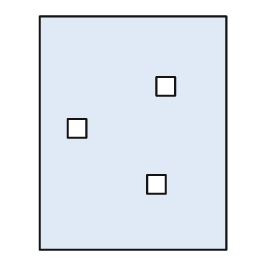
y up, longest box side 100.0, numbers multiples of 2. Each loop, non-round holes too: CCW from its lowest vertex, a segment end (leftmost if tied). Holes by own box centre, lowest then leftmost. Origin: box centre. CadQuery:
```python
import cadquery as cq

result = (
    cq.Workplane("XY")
    .moveTo(-40.0, -50.0)
    .lineTo(40.0, -50.0)
    .lineTo(40.0, 50.0)
    .lineTo(-40.0, 50.0)
    .close()
    .moveTo(6.0, -26.0)
    .lineTo(14.0, -26.0)
    .lineTo(14.0, -18.0)
    .lineTo(6.0, -18.0)
    .close()
    .moveTo(-28.0, -2.0)
    .lineTo(-20.0, -2.0)
    .lineTo(-20.0, 6.0)
    .lineTo(-28.0, 6.0)
    .close()
    .moveTo(10.0, 16.0)
    .lineTo(18.0, 16.0)
    .lineTo(18.0, 24.0)
    .lineTo(10.0, 24.0)
    .close()
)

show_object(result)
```